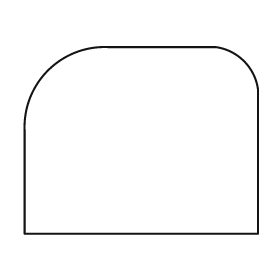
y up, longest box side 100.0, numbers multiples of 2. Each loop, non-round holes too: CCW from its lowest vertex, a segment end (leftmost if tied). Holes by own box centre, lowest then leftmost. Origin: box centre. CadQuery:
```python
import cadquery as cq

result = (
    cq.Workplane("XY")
    .moveTo(-50.0, -40.0)
    .lineTo(50.0, -40.0)
    .lineTo(50.0, 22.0)
    .threePointArc((44.0, 34.0), (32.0, 40.0))
    .lineTo(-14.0, 40.0)
    .threePointArc((-40.0, 30.0), (-50.0, 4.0))
    .close()
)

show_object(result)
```